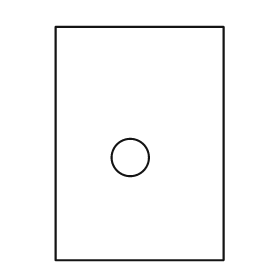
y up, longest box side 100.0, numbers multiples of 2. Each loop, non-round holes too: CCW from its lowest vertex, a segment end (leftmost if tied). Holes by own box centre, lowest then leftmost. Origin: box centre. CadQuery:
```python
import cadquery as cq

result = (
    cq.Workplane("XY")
    .moveTo(-36.0, -50.0)
    .lineTo(36.0, -50.0)
    .lineTo(36.0, 50.0)
    .lineTo(-36.0, 50.0)
    .close()
    .moveTo(-4.0, -6.0)
    .circle(8.0)
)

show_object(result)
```